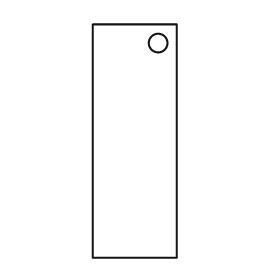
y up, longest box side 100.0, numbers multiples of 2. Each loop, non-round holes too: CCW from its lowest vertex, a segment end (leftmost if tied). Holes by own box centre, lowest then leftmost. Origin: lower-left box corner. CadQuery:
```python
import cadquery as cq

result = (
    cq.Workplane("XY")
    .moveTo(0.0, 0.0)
    .lineTo(36.0, 0.0)
    .lineTo(36.0, 100.0)
    .lineTo(0.0, 100.0)
    .close()
    .moveTo(28.0, 92.0)
    .circle(4.0)
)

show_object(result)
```